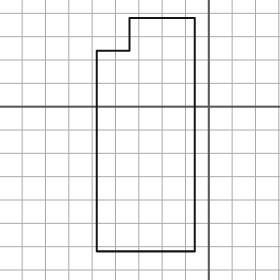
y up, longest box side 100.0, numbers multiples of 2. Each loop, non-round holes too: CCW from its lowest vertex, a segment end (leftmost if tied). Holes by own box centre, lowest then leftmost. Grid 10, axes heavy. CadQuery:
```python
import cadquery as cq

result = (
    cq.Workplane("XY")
    .moveTo(-48.0, -62.0)
    .lineTo(-6.0, -62.0)
    .lineTo(-6.0, 38.0)
    .lineTo(-34.0, 38.0)
    .lineTo(-34.0, 24.0)
    .lineTo(-48.0, 24.0)
    .close()
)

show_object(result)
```